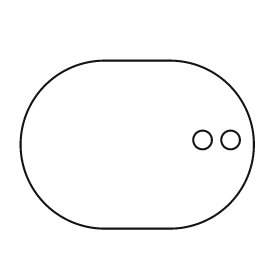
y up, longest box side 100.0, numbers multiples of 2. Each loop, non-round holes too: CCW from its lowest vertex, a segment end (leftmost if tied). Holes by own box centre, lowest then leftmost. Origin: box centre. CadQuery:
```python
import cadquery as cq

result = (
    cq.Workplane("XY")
    .moveTo(-14.0, -36.0)
    .lineTo(14.0, -36.0)
    .threePointArc((50.0, 0.0), (14.0, 36.0))
    .lineTo(-14.0, 36.0)
    .threePointArc((-50.0, 0.0), (-14.0, -36.0))
    .close()
    .moveTo(28.0, 2.0)
    .circle(4.0)
    .moveTo(40.0, 2.0)
    .circle(4.0)
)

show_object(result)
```